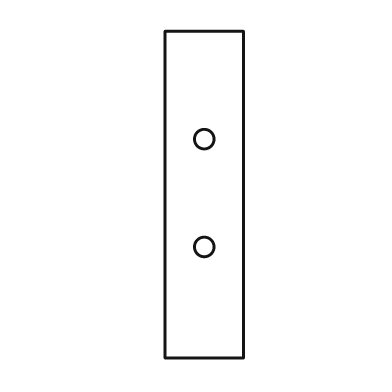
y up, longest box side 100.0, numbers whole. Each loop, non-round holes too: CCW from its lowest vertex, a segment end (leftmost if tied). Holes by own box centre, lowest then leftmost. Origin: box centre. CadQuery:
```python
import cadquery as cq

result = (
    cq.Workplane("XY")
    .moveTo(-12.0, -50.0)
    .lineTo(12.0, -50.0)
    .lineTo(12.0, 50.0)
    .lineTo(-12.0, 50.0)
    .close()
    .moveTo(0.0, -16.0)
    .circle(3.0)
    .moveTo(0.0, 17.0)
    .circle(3.0)
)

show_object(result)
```